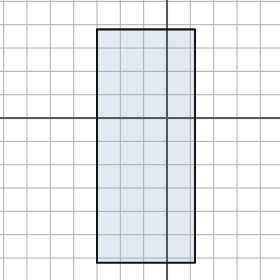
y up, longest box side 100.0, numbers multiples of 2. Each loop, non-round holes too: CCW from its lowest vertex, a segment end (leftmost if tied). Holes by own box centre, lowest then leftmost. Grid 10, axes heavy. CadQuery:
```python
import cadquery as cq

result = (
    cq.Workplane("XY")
    .moveTo(-30.0, -62.0)
    .lineTo(12.0, -62.0)
    .lineTo(12.0, 38.0)
    .lineTo(-30.0, 38.0)
    .close()
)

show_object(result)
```